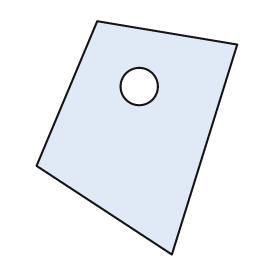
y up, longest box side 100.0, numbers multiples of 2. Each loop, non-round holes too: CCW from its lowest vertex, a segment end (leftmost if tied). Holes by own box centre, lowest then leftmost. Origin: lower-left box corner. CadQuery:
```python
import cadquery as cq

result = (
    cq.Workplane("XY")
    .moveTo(58.0, 0.0)
    .lineTo(86.0, 90.0)
    .lineTo(26.0, 100.0)
    .lineTo(0.0, 38.0)
    .close()
    .moveTo(44.0, 72.0)
    .circle(8.0)
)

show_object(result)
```